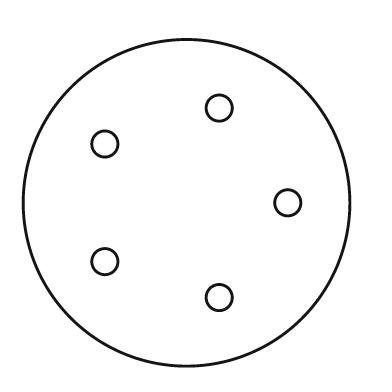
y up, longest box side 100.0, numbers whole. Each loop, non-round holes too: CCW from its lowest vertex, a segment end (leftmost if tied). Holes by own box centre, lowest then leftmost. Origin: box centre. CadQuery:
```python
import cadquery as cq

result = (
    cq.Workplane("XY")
    .moveTo(0.0, 0.0)
    .circle(50.0)
    .moveTo(10.0, -29.0)
    .circle(4.0)
    .moveTo(-25.0, -18.0)
    .circle(4.0)
    .moveTo(31.0, 0.0)
    .circle(4.0)
    .moveTo(-25.0, 18.0)
    .circle(4.0)
    .moveTo(10.0, 29.0)
    .circle(4.0)
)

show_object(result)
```